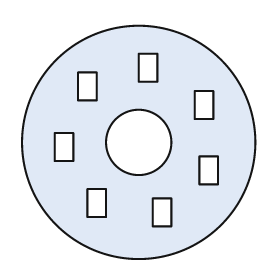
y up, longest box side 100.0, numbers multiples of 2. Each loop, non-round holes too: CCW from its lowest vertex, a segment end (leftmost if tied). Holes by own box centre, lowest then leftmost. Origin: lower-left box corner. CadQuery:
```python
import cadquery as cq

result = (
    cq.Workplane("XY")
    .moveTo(50.0, 50.0)
    .circle(50.0)
    .moveTo(56.0, 14.0)
    .lineTo(64.0, 14.0)
    .lineTo(64.0, 26.0)
    .lineTo(56.0, 26.0)
    .close()
    .moveTo(28.0, 18.0)
    .lineTo(36.0, 18.0)
    .lineTo(36.0, 30.0)
    .lineTo(28.0, 30.0)
    .close()
    .moveTo(76.0, 32.0)
    .lineTo(84.0, 32.0)
    .lineTo(84.0, 44.0)
    .lineTo(76.0, 44.0)
    .close()
    .moveTo(14.0, 42.0)
    .lineTo(22.0, 42.0)
    .lineTo(22.0, 54.0)
    .lineTo(14.0, 54.0)
    .close()
    .moveTo(50.0, 50.0)
    .circle(14.0)
    .moveTo(74.0, 60.0)
    .lineTo(82.0, 60.0)
    .lineTo(82.0, 72.0)
    .lineTo(74.0, 72.0)
    .close()
    .moveTo(24.0, 68.0)
    .lineTo(32.0, 68.0)
    .lineTo(32.0, 80.0)
    .lineTo(24.0, 80.0)
    .close()
    .moveTo(50.0, 76.0)
    .lineTo(58.0, 76.0)
    .lineTo(58.0, 88.0)
    .lineTo(50.0, 88.0)
    .close()
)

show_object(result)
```